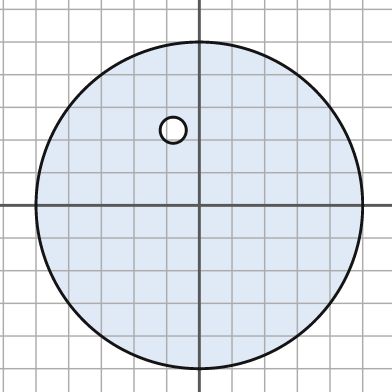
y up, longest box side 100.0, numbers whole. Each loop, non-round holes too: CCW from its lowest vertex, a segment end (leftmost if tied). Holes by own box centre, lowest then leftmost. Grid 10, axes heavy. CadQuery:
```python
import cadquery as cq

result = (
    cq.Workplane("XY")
    .moveTo(0.0, 0.0)
    .circle(50.0)
    .moveTo(-8.0, 23.0)
    .circle(4.0)
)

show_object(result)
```